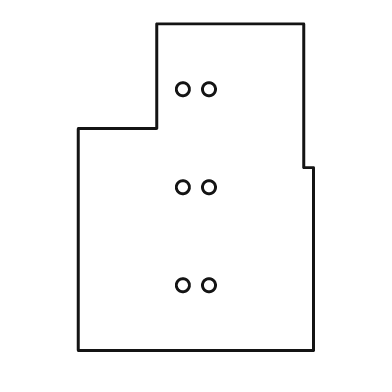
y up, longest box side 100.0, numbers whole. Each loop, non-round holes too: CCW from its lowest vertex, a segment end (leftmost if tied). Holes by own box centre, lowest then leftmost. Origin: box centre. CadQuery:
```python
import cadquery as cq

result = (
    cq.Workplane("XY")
    .moveTo(-36.0, -50.0)
    .lineTo(36.0, -50.0)
    .lineTo(36.0, 6.0)
    .lineTo(33.0, 6.0)
    .lineTo(33.0, 50.0)
    .lineTo(-12.0, 50.0)
    .lineTo(-12.0, 18.0)
    .lineTo(-36.0, 18.0)
    .close()
    .moveTo(-4.0, -30.0)
    .circle(2.0)
    .moveTo(4.0, -30.0)
    .circle(2.0)
    .moveTo(-4.0, 0.0)
    .circle(2.0)
    .moveTo(4.0, 0.0)
    .circle(2.0)
    .moveTo(-4.0, 30.0)
    .circle(2.0)
    .moveTo(4.0, 30.0)
    .circle(2.0)
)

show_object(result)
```